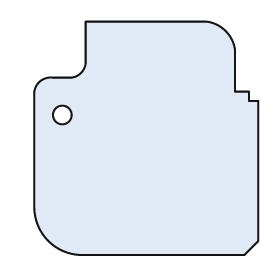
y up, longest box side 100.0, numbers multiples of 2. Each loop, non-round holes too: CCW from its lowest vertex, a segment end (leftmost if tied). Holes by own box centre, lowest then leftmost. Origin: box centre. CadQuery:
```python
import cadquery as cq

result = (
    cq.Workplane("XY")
    .moveTo(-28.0, -50.0)
    .lineTo(42.0, -50.0)
    .lineTo(48.0, -44.0)
    .lineTo(48.0, 16.0)
    .lineTo(44.0, 16.0)
    .lineTo(44.0, 20.0)
    .lineTo(38.0, 20.0)
    .lineTo(38.0, 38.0)
    .threePointArc((34.0, 46.0), (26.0, 50.0))
    .lineTo(-26.0, 50.0)
    .lineTo(-26.0, 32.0)
    .threePointArc((-28.0, 28.0), (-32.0, 26.0))
    .lineTo(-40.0, 26.0)
    .threePointArc((-46.0, 24.0), (-48.0, 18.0))
    .lineTo(-48.0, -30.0)
    .threePointArc((-42.0, -44.0), (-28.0, -50.0))
    .close()
    .moveTo(-36.0, 10.0)
    .circle(4.0)
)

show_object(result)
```